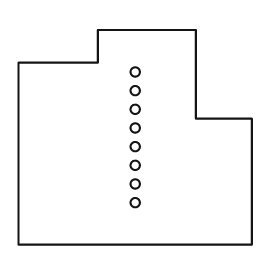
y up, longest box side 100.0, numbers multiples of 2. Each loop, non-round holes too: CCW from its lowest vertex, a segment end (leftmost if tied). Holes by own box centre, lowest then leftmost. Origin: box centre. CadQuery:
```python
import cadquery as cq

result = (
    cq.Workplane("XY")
    .moveTo(-50.0, -46.0)
    .lineTo(50.0, -46.0)
    .lineTo(50.0, 8.0)
    .lineTo(26.0, 8.0)
    .lineTo(26.0, 46.0)
    .lineTo(-16.0, 46.0)
    .lineTo(-16.0, 32.0)
    .lineTo(-50.0, 32.0)
    .close()
    .moveTo(0.0, -28.0)
    .circle(2.0)
    .moveTo(0.0, -20.0)
    .circle(2.0)
    .moveTo(0.0, -12.0)
    .circle(2.0)
    .moveTo(0.0, -4.0)
    .circle(2.0)
    .moveTo(0.0, 4.0)
    .circle(2.0)
    .moveTo(0.0, 12.0)
    .circle(2.0)
    .moveTo(0.0, 20.0)
    .circle(2.0)
    .moveTo(0.0, 28.0)
    .circle(2.0)
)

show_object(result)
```